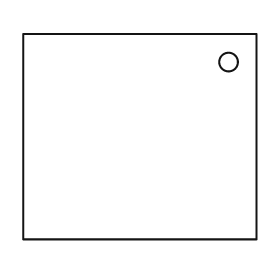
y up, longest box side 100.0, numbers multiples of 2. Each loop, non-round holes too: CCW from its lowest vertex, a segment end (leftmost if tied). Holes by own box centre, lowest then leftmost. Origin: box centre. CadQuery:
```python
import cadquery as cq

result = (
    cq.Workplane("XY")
    .moveTo(-50.0, -44.0)
    .lineTo(50.0, -44.0)
    .lineTo(50.0, 44.0)
    .lineTo(-50.0, 44.0)
    .close()
    .moveTo(38.0, 32.0)
    .circle(4.0)
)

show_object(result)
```